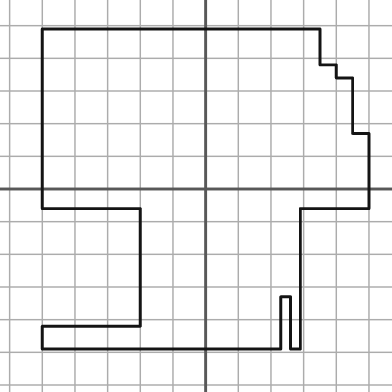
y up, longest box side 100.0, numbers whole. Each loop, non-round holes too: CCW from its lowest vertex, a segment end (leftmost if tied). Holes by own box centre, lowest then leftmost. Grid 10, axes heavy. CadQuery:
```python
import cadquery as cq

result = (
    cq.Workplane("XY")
    .moveTo(-50.0, -49.0)
    .lineTo(23.0, -49.0)
    .lineTo(23.0, -33.0)
    .lineTo(26.0, -33.0)
    .lineTo(26.0, -49.0)
    .lineTo(29.0, -49.0)
    .lineTo(29.0, -6.0)
    .lineTo(50.0, -6.0)
    .lineTo(50.0, 17.0)
    .lineTo(45.0, 17.0)
    .lineTo(45.0, 34.0)
    .lineTo(40.0, 34.0)
    .lineTo(40.0, 38.0)
    .lineTo(35.0, 38.0)
    .lineTo(35.0, 49.0)
    .lineTo(-50.0, 49.0)
    .lineTo(-50.0, -6.0)
    .lineTo(-20.0, -6.0)
    .lineTo(-20.0, -42.0)
    .lineTo(-50.0, -42.0)
    .close()
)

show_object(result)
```